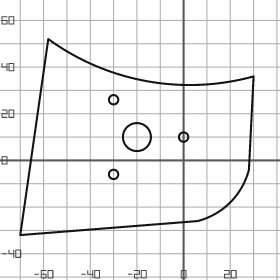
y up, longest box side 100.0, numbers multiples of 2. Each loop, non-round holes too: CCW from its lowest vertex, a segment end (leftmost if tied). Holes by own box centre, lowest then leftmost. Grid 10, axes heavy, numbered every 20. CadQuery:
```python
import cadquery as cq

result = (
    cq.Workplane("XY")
    .moveTo(-70.0, -32.0)
    .lineTo(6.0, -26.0)
    .threePointArc((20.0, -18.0), (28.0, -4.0))
    .lineTo(30.0, 36.0)
    .threePointArc((-16.0, 34.0), (-58.0, 52.0))
    .close()
    .moveTo(-30.0, -6.0)
    .circle(2.0)
    .moveTo(-20.0, 10.0)
    .circle(6.0)
    .moveTo(0.0, 10.0)
    .circle(2.0)
    .moveTo(-30.0, 26.0)
    .circle(2.0)
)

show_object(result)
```